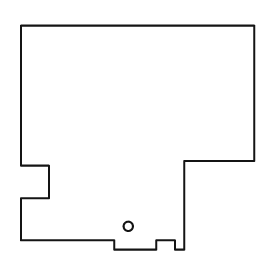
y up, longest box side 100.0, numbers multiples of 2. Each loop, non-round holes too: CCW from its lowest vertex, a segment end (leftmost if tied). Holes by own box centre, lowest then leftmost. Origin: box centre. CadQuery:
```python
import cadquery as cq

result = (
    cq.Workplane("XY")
    .moveTo(-10.0, -48.0)
    .lineTo(8.0, -48.0)
    .lineTo(8.0, -44.0)
    .lineTo(16.0, -44.0)
    .lineTo(16.0, -48.0)
    .lineTo(20.0, -48.0)
    .lineTo(20.0, -10.0)
    .lineTo(50.0, -10.0)
    .lineTo(50.0, 48.0)
    .lineTo(-50.0, 48.0)
    .lineTo(-50.0, -12.0)
    .lineTo(-38.0, -12.0)
    .lineTo(-38.0, -26.0)
    .lineTo(-50.0, -26.0)
    .lineTo(-50.0, -44.0)
    .lineTo(-10.0, -44.0)
    .close()
    .moveTo(-4.0, -38.0)
    .circle(2.0)
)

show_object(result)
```